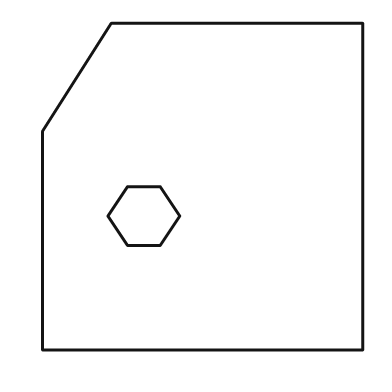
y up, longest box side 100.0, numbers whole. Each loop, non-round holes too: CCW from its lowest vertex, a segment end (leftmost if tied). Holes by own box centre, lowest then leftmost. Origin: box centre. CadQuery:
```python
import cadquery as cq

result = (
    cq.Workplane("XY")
    .moveTo(-49.0, -50.0)
    .lineTo(49.0, -50.0)
    .lineTo(49.0, 50.0)
    .lineTo(-28.0, 50.0)
    .lineTo(-49.0, 17.0)
    .close()
    .moveTo(-23.0, -18.0)
    .lineTo(-13.0, -18.0)
    .lineTo(-7.0, -9.0)
    .lineTo(-13.0, 0.0)
    .lineTo(-23.0, 0.0)
    .lineTo(-29.0, -9.0)
    .close()
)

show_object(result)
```